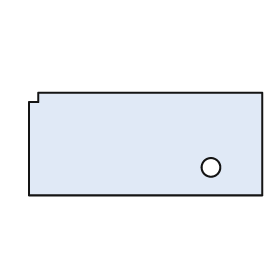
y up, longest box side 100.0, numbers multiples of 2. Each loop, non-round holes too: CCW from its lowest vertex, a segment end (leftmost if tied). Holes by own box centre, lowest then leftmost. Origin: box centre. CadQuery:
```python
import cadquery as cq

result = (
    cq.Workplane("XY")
    .moveTo(-50.0, -22.0)
    .lineTo(50.0, -22.0)
    .lineTo(50.0, 22.0)
    .lineTo(-46.0, 22.0)
    .lineTo(-46.0, 18.0)
    .lineTo(-50.0, 18.0)
    .close()
    .moveTo(28.0, -10.0)
    .circle(4.0)
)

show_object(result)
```